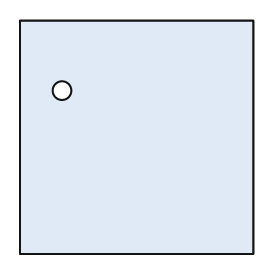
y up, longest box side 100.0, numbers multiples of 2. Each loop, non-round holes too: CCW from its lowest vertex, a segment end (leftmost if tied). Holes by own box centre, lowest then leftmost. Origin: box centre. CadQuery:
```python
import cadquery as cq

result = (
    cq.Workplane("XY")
    .moveTo(-50.0, -50.0)
    .lineTo(50.0, -50.0)
    .lineTo(50.0, 50.0)
    .lineTo(-50.0, 50.0)
    .close()
    .moveTo(-32.0, 20.0)
    .circle(4.0)
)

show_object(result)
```